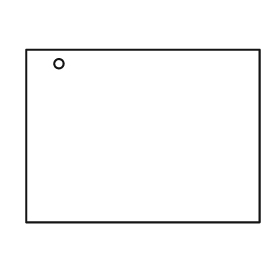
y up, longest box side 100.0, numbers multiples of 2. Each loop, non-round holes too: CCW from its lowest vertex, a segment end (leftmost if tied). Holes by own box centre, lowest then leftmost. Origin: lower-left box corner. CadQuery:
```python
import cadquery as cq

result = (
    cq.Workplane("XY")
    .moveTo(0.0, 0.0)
    .lineTo(100.0, 0.0)
    .lineTo(100.0, 74.0)
    .lineTo(0.0, 74.0)
    .close()
    .moveTo(14.0, 68.0)
    .circle(2.0)
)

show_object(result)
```